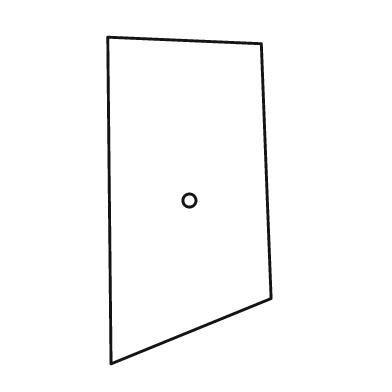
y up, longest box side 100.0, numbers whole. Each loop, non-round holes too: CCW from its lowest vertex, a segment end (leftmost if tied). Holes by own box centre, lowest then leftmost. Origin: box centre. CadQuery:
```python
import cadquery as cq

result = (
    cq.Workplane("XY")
    .moveTo(-24.0, -50.0)
    .lineTo(25.0, -30.0)
    .lineTo(22.0, 48.0)
    .lineTo(-25.0, 50.0)
    .close()
    .moveTo(0.0, 0.0)
    .circle(2.0)
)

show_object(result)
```